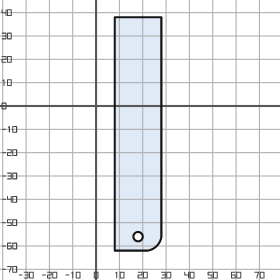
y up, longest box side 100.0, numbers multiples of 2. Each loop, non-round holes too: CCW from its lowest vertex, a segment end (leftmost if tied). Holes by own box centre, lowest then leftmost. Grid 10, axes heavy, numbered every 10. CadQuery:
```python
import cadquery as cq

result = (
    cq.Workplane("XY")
    .moveTo(8.0, -62.0)
    .lineTo(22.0, -62.0)
    .threePointArc((26.0, -60.0), (28.0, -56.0))
    .lineTo(28.0, 38.0)
    .lineTo(8.0, 38.0)
    .close()
    .moveTo(18.0, -56.0)
    .circle(2.0)
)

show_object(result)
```